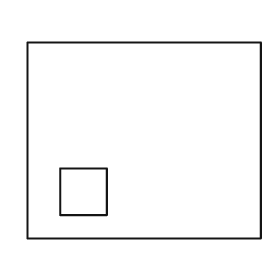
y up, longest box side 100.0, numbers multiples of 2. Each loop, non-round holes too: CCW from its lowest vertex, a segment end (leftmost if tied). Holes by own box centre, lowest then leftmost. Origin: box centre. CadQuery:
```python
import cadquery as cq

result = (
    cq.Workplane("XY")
    .moveTo(-50.0, -42.0)
    .lineTo(50.0, -42.0)
    .lineTo(50.0, 42.0)
    .lineTo(-50.0, 42.0)
    .close()
    .moveTo(-36.0, -32.0)
    .lineTo(-16.0, -32.0)
    .lineTo(-16.0, -12.0)
    .lineTo(-36.0, -12.0)
    .close()
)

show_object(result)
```